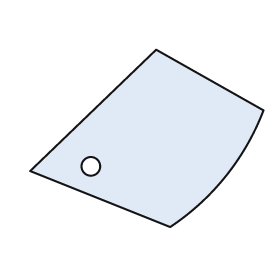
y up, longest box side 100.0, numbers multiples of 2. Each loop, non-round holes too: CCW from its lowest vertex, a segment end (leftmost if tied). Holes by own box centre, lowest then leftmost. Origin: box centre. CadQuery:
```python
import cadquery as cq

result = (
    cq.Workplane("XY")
    .moveTo(10.0, -38.0)
    .threePointArc((34.0, -16.0), (50.0, 12.0))
    .lineTo(4.0, 38.0)
    .lineTo(-50.0, -14.0)
    .close()
    .moveTo(-24.0, -12.0)
    .circle(4.0)
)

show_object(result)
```